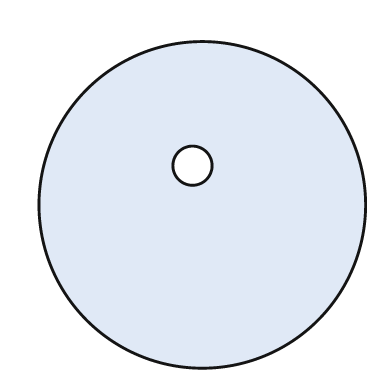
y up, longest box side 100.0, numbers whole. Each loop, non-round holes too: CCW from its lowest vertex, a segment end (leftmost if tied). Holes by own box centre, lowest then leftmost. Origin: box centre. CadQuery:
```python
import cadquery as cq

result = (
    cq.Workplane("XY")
    .moveTo(0.0, 0.0)
    .circle(50.0)
    .moveTo(-3.0, 12.0)
    .circle(6.0)
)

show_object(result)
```